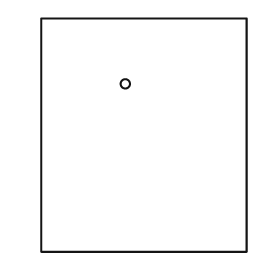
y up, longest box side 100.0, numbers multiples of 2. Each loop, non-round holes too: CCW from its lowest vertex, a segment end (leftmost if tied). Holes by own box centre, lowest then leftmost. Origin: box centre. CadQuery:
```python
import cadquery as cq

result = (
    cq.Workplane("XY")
    .moveTo(-44.0, -50.0)
    .lineTo(44.0, -50.0)
    .lineTo(44.0, 50.0)
    .lineTo(-44.0, 50.0)
    .close()
    .moveTo(-8.0, 22.0)
    .circle(2.0)
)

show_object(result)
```